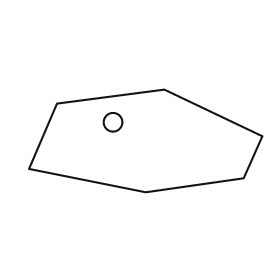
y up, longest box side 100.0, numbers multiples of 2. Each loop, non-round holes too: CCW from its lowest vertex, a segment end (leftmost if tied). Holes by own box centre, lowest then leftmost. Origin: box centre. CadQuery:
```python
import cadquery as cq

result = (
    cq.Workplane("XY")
    .moveTo(0.0, -22.0)
    .lineTo(42.0, -16.0)
    .lineTo(50.0, 2.0)
    .lineTo(8.0, 22.0)
    .lineTo(-38.0, 16.0)
    .lineTo(-50.0, -12.0)
    .close()
    .moveTo(-14.0, 8.0)
    .circle(4.0)
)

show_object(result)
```